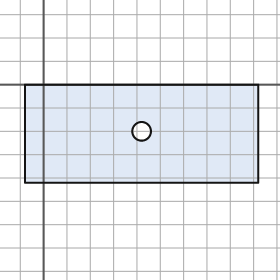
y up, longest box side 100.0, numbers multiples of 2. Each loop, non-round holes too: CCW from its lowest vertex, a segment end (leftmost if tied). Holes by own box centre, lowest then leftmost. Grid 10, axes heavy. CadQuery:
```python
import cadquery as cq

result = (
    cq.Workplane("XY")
    .moveTo(-8.0, -42.0)
    .lineTo(92.0, -42.0)
    .lineTo(92.0, 0.0)
    .lineTo(-8.0, 0.0)
    .close()
    .moveTo(42.0, -20.0)
    .circle(4.0)
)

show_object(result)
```